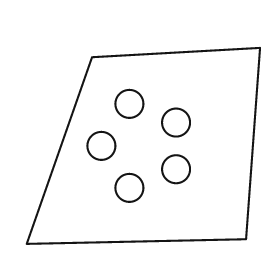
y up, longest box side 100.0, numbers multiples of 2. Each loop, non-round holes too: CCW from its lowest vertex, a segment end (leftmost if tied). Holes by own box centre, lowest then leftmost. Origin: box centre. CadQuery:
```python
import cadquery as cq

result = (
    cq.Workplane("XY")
    .moveTo(-50.0, -42.0)
    .lineTo(44.0, -40.0)
    .lineTo(50.0, 42.0)
    .lineTo(-22.0, 38.0)
    .close()
    .moveTo(-6.0, -18.0)
    .circle(6.0)
    .moveTo(14.0, -10.0)
    .circle(6.0)
    .moveTo(-18.0, 0.0)
    .circle(6.0)
    .moveTo(14.0, 10.0)
    .circle(6.0)
    .moveTo(-6.0, 18.0)
    .circle(6.0)
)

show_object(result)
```